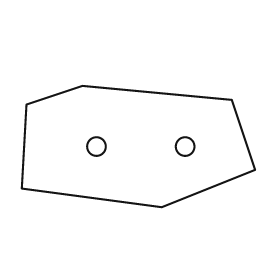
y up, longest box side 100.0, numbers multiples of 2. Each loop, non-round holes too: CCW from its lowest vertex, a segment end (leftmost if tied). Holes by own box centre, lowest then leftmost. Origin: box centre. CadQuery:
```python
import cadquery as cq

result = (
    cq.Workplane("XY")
    .moveTo(10.0, -26.0)
    .lineTo(50.0, -10.0)
    .lineTo(40.0, 20.0)
    .lineTo(-24.0, 26.0)
    .lineTo(-48.0, 18.0)
    .lineTo(-50.0, -18.0)
    .close()
    .moveTo(-18.0, 0.0)
    .circle(4.0)
    .moveTo(20.0, 0.0)
    .circle(4.0)
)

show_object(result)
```